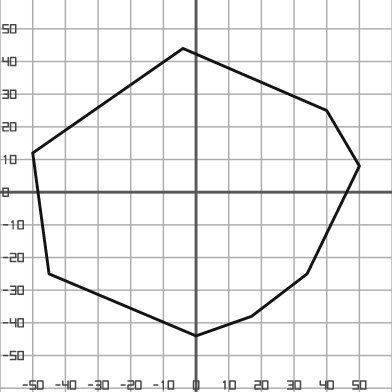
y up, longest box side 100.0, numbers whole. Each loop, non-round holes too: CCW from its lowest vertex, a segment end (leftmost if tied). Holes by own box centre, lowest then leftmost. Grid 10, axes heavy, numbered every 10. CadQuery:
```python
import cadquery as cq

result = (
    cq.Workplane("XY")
    .moveTo(0.0, -44.0)
    .lineTo(17.0, -38.0)
    .lineTo(34.0, -25.0)
    .lineTo(50.0, 8.0)
    .lineTo(40.0, 25.0)
    .lineTo(-4.0, 44.0)
    .lineTo(-50.0, 12.0)
    .lineTo(-45.0, -25.0)
    .close()
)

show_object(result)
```